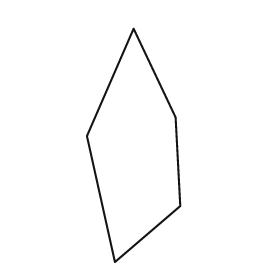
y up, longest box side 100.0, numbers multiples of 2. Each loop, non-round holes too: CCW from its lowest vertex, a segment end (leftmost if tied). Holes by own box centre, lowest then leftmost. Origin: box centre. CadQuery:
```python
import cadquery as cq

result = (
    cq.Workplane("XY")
    .moveTo(-8.0, -50.0)
    .lineTo(20.0, -26.0)
    .lineTo(18.0, 12.0)
    .lineTo(0.0, 50.0)
    .lineTo(-20.0, 4.0)
    .close()
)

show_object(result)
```